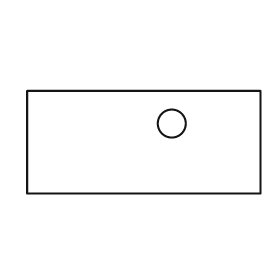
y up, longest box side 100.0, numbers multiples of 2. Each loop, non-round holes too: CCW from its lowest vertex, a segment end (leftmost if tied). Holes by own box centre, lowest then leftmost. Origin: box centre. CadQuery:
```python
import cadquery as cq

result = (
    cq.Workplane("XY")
    .moveTo(-50.0, -22.0)
    .lineTo(50.0, -22.0)
    .lineTo(50.0, 22.0)
    .lineTo(-50.0, 22.0)
    .close()
    .moveTo(12.0, 8.0)
    .circle(6.0)
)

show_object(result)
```